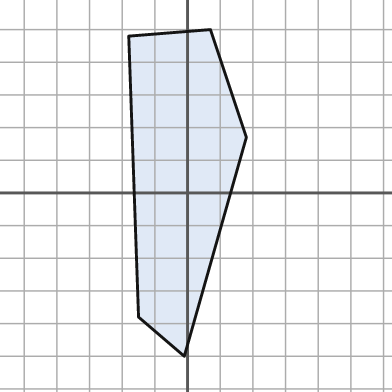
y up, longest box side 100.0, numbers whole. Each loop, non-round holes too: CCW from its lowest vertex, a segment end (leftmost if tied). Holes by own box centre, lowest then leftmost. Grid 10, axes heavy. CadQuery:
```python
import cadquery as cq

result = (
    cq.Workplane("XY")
    .moveTo(-1.0, -50.0)
    .lineTo(18.0, 17.0)
    .lineTo(7.0, 50.0)
    .lineTo(-18.0, 48.0)
    .lineTo(-15.0, -38.0)
    .close()
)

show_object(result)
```